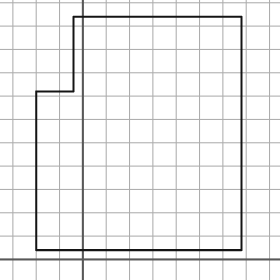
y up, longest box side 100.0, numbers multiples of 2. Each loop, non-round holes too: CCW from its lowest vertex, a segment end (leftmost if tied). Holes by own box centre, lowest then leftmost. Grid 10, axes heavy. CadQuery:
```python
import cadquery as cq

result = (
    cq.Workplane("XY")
    .moveTo(-20.0, 4.0)
    .lineTo(68.0, 4.0)
    .lineTo(68.0, 104.0)
    .lineTo(-4.0, 104.0)
    .lineTo(-4.0, 72.0)
    .lineTo(-20.0, 72.0)
    .close()
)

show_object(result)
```